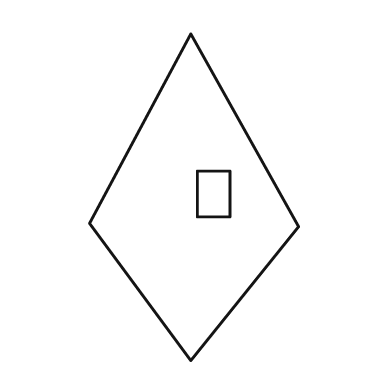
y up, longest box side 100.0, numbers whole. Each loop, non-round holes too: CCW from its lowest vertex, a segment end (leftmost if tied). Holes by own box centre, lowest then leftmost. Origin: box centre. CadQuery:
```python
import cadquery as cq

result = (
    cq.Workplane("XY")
    .moveTo(-1.0, -50.0)
    .lineTo(32.0, -9.0)
    .lineTo(-1.0, 50.0)
    .lineTo(-32.0, -8.0)
    .close()
    .moveTo(1.0, -6.0)
    .lineTo(11.0, -6.0)
    .lineTo(11.0, 8.0)
    .lineTo(1.0, 8.0)
    .close()
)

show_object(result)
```